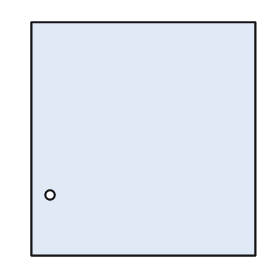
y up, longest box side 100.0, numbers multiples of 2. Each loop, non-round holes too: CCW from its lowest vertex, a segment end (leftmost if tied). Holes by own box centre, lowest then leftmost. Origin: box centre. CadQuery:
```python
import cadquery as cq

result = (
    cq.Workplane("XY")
    .moveTo(-48.0, -50.0)
    .lineTo(48.0, -50.0)
    .lineTo(48.0, 50.0)
    .lineTo(-48.0, 50.0)
    .close()
    .moveTo(-40.0, -24.0)
    .circle(2.0)
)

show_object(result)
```